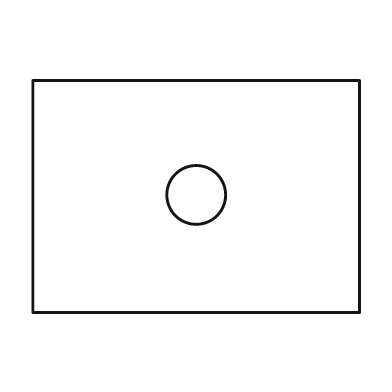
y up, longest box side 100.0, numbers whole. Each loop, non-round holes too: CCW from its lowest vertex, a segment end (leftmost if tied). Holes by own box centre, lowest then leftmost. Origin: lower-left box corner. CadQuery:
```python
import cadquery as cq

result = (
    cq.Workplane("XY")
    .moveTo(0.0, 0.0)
    .lineTo(100.0, 0.0)
    .lineTo(100.0, 71.0)
    .lineTo(0.0, 71.0)
    .close()
    .moveTo(50.0, 36.0)
    .circle(9.0)
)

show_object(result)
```